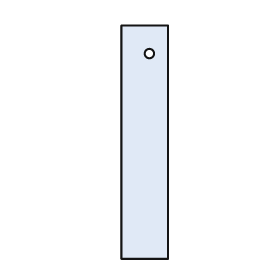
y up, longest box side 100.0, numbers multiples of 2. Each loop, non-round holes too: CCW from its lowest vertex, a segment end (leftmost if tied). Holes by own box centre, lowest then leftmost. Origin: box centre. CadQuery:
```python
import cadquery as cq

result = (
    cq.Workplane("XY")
    .moveTo(-10.0, -50.0)
    .lineTo(10.0, -50.0)
    .lineTo(10.0, 50.0)
    .lineTo(-10.0, 50.0)
    .close()
    .moveTo(2.0, 38.0)
    .circle(2.0)
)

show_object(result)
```